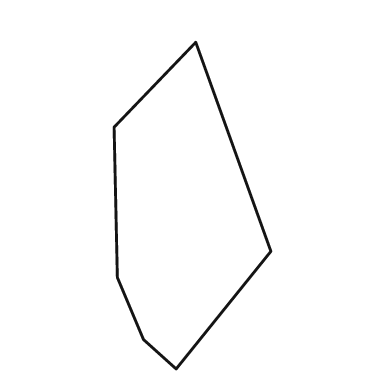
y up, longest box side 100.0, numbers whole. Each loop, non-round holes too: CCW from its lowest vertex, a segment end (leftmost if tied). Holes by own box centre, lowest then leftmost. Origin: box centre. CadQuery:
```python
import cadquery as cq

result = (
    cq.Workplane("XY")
    .moveTo(-5.0, -50.0)
    .lineTo(24.0, -14.0)
    .lineTo(1.0, 50.0)
    .lineTo(-24.0, 24.0)
    .lineTo(-23.0, -22.0)
    .lineTo(-15.0, -41.0)
    .close()
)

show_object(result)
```